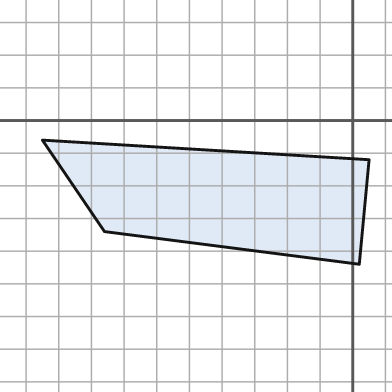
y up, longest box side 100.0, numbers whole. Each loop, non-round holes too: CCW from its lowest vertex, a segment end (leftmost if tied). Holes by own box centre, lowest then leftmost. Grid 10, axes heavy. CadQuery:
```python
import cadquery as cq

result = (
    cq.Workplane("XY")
    .moveTo(2.0, -44.0)
    .lineTo(5.0, -12.0)
    .lineTo(-95.0, -6.0)
    .lineTo(-76.0, -34.0)
    .close()
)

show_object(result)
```